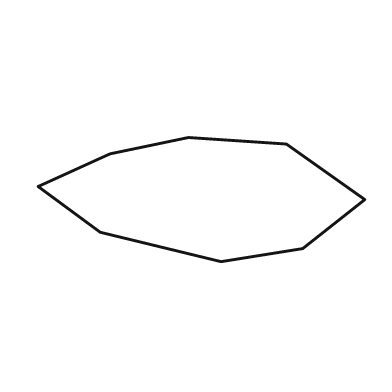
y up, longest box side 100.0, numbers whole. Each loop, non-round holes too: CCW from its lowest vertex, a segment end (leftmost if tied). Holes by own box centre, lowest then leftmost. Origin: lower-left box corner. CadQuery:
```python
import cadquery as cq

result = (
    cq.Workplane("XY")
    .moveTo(56.0, 0.0)
    .lineTo(81.0, 4.0)
    .lineTo(100.0, 19.0)
    .lineTo(76.0, 36.0)
    .lineTo(46.0, 38.0)
    .lineTo(22.0, 33.0)
    .lineTo(0.0, 23.0)
    .lineTo(19.0, 9.0)
    .close()
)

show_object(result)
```